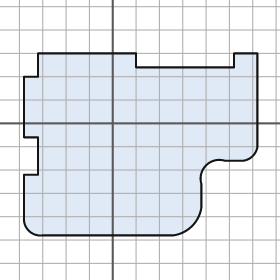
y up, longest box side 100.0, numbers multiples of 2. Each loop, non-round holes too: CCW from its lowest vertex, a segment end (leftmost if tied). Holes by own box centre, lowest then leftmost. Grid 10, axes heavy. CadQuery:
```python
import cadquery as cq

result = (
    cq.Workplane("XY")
    .moveTo(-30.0, -48.0)
    .lineTo(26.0, -48.0)
    .threePointArc((34.0, -44.0), (38.0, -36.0))
    .lineTo(38.0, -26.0)
    .threePointArc((40.0, -18.0), (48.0, -16.0))
    .lineTo(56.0, -16.0)
    .threePointArc((60.0, -14.0), (62.0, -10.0))
    .lineTo(62.0, 30.0)
    .lineTo(52.0, 30.0)
    .lineTo(52.0, 24.0)
    .lineTo(10.0, 24.0)
    .lineTo(10.0, 30.0)
    .lineTo(-32.0, 30.0)
    .lineTo(-32.0, 20.0)
    .lineTo(-38.0, 20.0)
    .lineTo(-38.0, -6.0)
    .lineTo(-32.0, -6.0)
    .lineTo(-32.0, -22.0)
    .lineTo(-38.0, -22.0)
    .lineTo(-38.0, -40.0)
    .threePointArc((-36.0, -46.0), (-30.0, -48.0))
    .close()
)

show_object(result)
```